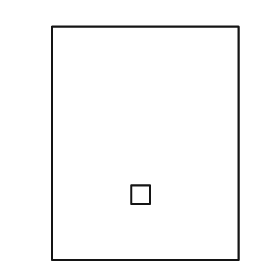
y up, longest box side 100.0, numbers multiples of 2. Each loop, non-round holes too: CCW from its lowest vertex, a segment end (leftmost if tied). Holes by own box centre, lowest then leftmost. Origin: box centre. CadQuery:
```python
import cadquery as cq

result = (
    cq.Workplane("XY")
    .moveTo(-40.0, -50.0)
    .lineTo(40.0, -50.0)
    .lineTo(40.0, 50.0)
    .lineTo(-40.0, 50.0)
    .close()
    .moveTo(-6.0, -26.0)
    .lineTo(2.0, -26.0)
    .lineTo(2.0, -18.0)
    .lineTo(-6.0, -18.0)
    .close()
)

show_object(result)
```